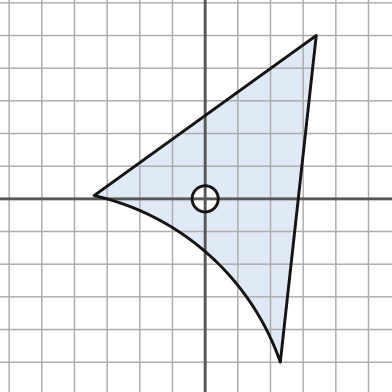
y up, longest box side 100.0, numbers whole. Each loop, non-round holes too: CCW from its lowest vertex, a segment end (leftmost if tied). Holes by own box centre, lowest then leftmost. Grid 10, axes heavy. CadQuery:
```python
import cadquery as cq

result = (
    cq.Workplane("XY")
    .moveTo(23.0, -50.0)
    .lineTo(34.0, 50.0)
    .lineTo(-34.0, 1.0)
    .threePointArc((1.0, -17.0), (23.0, -50.0))
    .close()
    .moveTo(0.0, 0.0)
    .circle(4.0)
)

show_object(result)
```